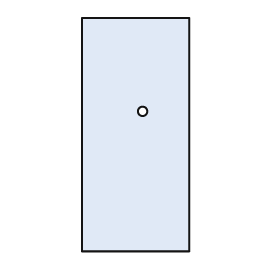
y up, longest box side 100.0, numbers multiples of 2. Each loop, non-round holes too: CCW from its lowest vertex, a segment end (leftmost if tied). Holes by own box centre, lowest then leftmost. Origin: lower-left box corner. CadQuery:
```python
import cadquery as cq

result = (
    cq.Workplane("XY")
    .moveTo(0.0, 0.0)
    .lineTo(46.0, 0.0)
    .lineTo(46.0, 100.0)
    .lineTo(0.0, 100.0)
    .close()
    .moveTo(26.0, 60.0)
    .circle(2.0)
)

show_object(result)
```